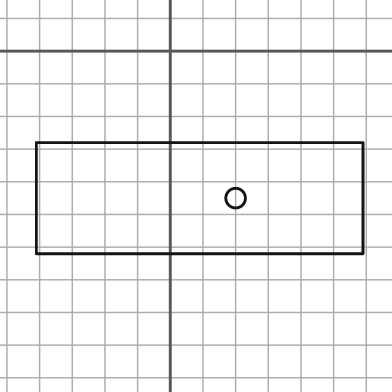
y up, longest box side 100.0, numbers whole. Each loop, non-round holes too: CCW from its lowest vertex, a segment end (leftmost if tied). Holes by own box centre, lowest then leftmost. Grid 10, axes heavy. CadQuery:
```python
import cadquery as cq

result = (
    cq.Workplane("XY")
    .moveTo(-41.0, -62.0)
    .lineTo(59.0, -62.0)
    .lineTo(59.0, -28.0)
    .lineTo(-41.0, -28.0)
    .close()
    .moveTo(20.0, -45.0)
    .circle(3.0)
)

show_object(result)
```